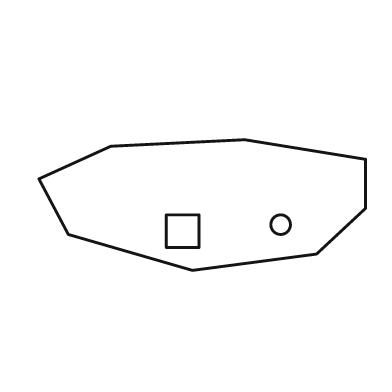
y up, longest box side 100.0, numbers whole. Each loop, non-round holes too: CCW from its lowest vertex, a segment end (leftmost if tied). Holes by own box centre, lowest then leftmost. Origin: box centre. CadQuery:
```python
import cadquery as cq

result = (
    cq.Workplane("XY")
    .moveTo(-3.0, -20.0)
    .lineTo(35.0, -15.0)
    .lineTo(50.0, -1.0)
    .lineTo(50.0, 14.0)
    .lineTo(13.0, 20.0)
    .lineTo(-28.0, 18.0)
    .lineTo(-50.0, 8.0)
    .lineTo(-41.0, -9.0)
    .close()
    .moveTo(-11.0, -13.0)
    .lineTo(-1.0, -13.0)
    .lineTo(-1.0, -3.0)
    .lineTo(-11.0, -3.0)
    .close()
    .moveTo(24.0, -6.0)
    .circle(3.0)
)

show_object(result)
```